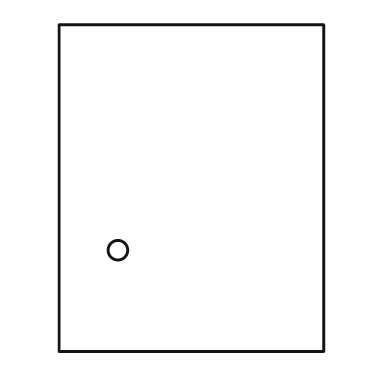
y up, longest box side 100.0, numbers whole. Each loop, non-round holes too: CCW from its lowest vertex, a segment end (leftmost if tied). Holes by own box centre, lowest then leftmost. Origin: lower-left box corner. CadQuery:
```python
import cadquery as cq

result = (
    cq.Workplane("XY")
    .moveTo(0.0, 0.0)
    .lineTo(81.0, 0.0)
    .lineTo(81.0, 100.0)
    .lineTo(0.0, 100.0)
    .close()
    .moveTo(18.0, 31.0)
    .circle(3.0)
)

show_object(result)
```